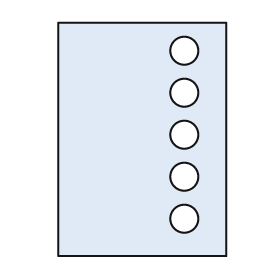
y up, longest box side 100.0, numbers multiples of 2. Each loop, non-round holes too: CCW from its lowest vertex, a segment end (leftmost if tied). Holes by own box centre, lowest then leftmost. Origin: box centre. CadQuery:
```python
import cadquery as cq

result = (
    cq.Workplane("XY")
    .moveTo(-36.0, -50.0)
    .lineTo(36.0, -50.0)
    .lineTo(36.0, 50.0)
    .lineTo(-36.0, 50.0)
    .close()
    .moveTo(18.0, -34.0)
    .circle(6.0)
    .moveTo(18.0, -16.0)
    .circle(6.0)
    .moveTo(18.0, 2.0)
    .circle(6.0)
    .moveTo(18.0, 20.0)
    .circle(6.0)
    .moveTo(18.0, 38.0)
    .circle(6.0)
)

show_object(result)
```